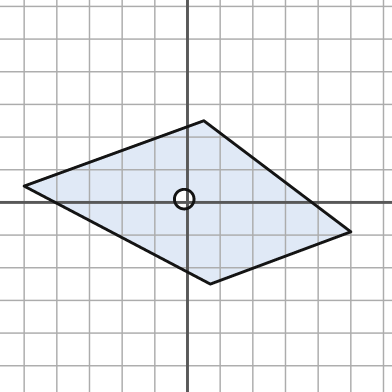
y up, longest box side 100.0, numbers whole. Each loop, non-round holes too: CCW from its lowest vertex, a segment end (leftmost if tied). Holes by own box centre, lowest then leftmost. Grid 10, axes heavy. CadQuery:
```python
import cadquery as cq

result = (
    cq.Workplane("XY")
    .moveTo(7.0, -25.0)
    .lineTo(50.0, -9.0)
    .lineTo(5.0, 25.0)
    .lineTo(-50.0, 5.0)
    .close()
    .moveTo(-1.0, 1.0)
    .circle(3.0)
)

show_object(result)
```